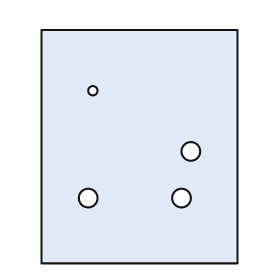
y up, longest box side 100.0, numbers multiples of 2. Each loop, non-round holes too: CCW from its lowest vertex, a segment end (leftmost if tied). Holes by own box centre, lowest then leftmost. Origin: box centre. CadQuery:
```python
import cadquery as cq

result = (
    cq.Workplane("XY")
    .moveTo(-42.0, -50.0)
    .lineTo(42.0, -50.0)
    .lineTo(42.0, 50.0)
    .lineTo(-42.0, 50.0)
    .close()
    .moveTo(-22.0, -22.0)
    .circle(4.0)
    .moveTo(18.0, -22.0)
    .circle(4.0)
    .moveTo(22.0, -2.0)
    .circle(4.0)
    .moveTo(-20.0, 24.0)
    .circle(2.0)
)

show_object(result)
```